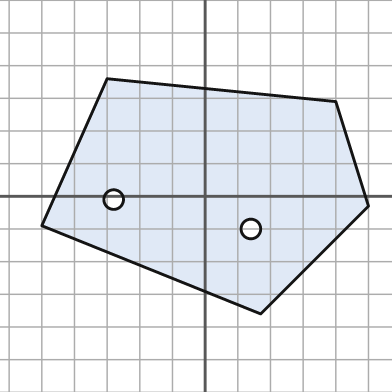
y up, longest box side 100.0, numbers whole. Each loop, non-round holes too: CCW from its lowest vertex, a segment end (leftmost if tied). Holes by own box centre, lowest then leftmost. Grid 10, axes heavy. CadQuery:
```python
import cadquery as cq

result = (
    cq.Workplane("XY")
    .moveTo(17.0, -36.0)
    .lineTo(50.0, -3.0)
    .lineTo(40.0, 29.0)
    .lineTo(-30.0, 36.0)
    .lineTo(-50.0, -9.0)
    .close()
    .moveTo(14.0, -10.0)
    .circle(3.0)
    .moveTo(-28.0, -1.0)
    .circle(3.0)
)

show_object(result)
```